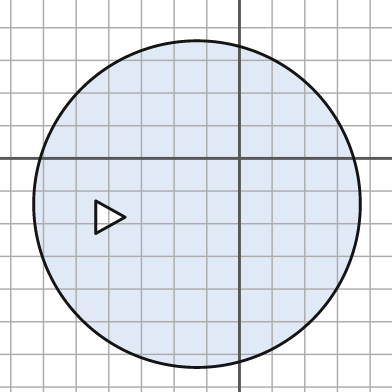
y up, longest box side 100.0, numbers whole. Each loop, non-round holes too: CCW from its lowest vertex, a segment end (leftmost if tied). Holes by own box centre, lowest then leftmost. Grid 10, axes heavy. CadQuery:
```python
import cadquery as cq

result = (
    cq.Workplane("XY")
    .moveTo(-13.0, -14.0)
    .circle(50.0)
    .moveTo(-44.0, -23.0)
    .lineTo(-35.0, -18.0)
    .lineTo(-44.0, -13.0)
    .close()
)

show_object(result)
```